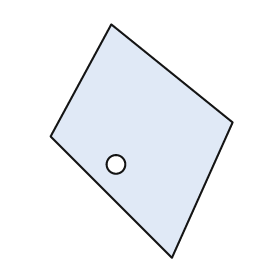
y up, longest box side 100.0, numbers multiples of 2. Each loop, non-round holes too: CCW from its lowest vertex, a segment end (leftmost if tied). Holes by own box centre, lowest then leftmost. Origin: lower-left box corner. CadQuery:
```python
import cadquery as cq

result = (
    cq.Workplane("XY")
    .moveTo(52.0, 0.0)
    .lineTo(78.0, 58.0)
    .lineTo(26.0, 100.0)
    .lineTo(0.0, 52.0)
    .close()
    .moveTo(28.0, 40.0)
    .circle(4.0)
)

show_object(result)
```